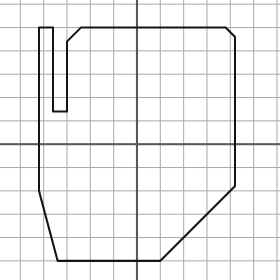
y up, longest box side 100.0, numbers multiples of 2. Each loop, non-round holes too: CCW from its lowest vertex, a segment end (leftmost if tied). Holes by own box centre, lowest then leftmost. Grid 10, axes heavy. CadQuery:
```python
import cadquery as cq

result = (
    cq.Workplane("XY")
    .moveTo(-34.0, -50.0)
    .lineTo(10.0, -50.0)
    .lineTo(42.0, -18.0)
    .lineTo(42.0, 46.0)
    .lineTo(38.0, 50.0)
    .lineTo(-24.0, 50.0)
    .lineTo(-30.0, 44.0)
    .lineTo(-30.0, 14.0)
    .lineTo(-36.0, 14.0)
    .lineTo(-36.0, 50.0)
    .lineTo(-42.0, 50.0)
    .lineTo(-42.0, -20.0)
    .close()
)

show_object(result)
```